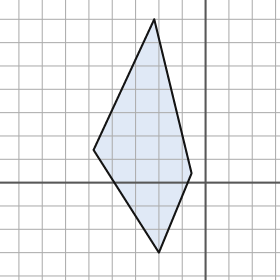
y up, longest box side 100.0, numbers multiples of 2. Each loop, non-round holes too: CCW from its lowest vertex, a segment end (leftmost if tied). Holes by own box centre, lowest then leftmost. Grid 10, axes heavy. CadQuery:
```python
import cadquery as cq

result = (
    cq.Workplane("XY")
    .moveTo(-20.0, -30.0)
    .lineTo(-6.0, 4.0)
    .lineTo(-22.0, 70.0)
    .lineTo(-48.0, 14.0)
    .close()
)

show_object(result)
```